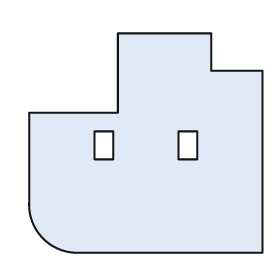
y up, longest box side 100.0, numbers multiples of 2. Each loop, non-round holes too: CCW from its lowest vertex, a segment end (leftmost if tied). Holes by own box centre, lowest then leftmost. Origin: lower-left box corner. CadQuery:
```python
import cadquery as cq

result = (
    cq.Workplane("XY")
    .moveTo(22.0, 0.0)
    .lineTo(100.0, 0.0)
    .lineTo(100.0, 78.0)
    .lineTo(78.0, 78.0)
    .lineTo(78.0, 94.0)
    .lineTo(38.0, 94.0)
    .lineTo(38.0, 60.0)
    .lineTo(0.0, 60.0)
    .lineTo(0.0, 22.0)
    .threePointArc((6.0, 6.0), (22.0, 0.0))
    .close()
    .moveTo(28.0, 40.0)
    .lineTo(36.0, 40.0)
    .lineTo(36.0, 52.0)
    .lineTo(28.0, 52.0)
    .close()
    .moveTo(64.0, 40.0)
    .lineTo(72.0, 40.0)
    .lineTo(72.0, 52.0)
    .lineTo(64.0, 52.0)
    .close()
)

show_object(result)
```